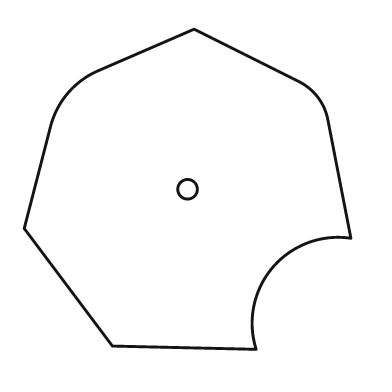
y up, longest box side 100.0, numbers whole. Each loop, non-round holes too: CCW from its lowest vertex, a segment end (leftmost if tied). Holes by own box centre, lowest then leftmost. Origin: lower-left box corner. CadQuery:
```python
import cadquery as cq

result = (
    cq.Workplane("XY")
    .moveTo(71.0, 0.0)
    .threePointArc((76.0, 25.0), (100.0, 34.0))
    .lineTo(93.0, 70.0)
    .threePointArc((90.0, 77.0), (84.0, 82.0))
    .lineTo(52.0, 98.0)
    .lineTo(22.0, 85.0)
    .threePointArc((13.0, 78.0), (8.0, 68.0))
    .lineTo(0.0, 37.0)
    .lineTo(27.0, 1.0)
    .close()
    .moveTo(50.0, 49.0)
    .circle(3.0)
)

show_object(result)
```